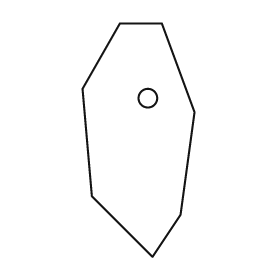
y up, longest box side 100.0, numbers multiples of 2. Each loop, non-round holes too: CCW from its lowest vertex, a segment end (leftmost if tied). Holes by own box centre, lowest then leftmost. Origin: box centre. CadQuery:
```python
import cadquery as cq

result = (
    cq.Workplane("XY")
    .moveTo(6.0, -50.0)
    .lineTo(18.0, -32.0)
    .lineTo(24.0, 12.0)
    .lineTo(10.0, 50.0)
    .lineTo(-8.0, 50.0)
    .lineTo(-24.0, 22.0)
    .lineTo(-20.0, -24.0)
    .close()
    .moveTo(4.0, 18.0)
    .circle(4.0)
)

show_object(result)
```